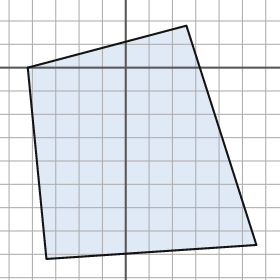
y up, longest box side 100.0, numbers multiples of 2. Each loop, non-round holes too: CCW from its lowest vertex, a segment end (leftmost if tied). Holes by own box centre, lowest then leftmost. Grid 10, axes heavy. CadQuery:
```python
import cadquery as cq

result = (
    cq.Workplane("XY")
    .moveTo(-34.0, -82.0)
    .lineTo(56.0, -76.0)
    .lineTo(26.0, 18.0)
    .lineTo(-42.0, 0.0)
    .close()
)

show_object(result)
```